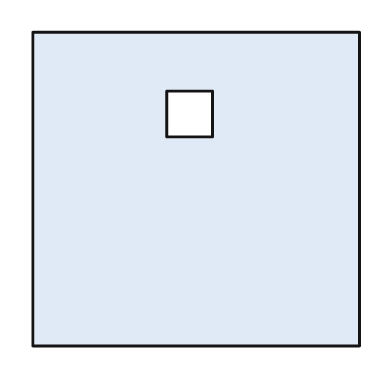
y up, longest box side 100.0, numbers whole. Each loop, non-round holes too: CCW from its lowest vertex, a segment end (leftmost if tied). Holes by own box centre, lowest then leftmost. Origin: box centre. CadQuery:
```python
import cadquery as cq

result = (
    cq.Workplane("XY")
    .moveTo(-50.0, -48.0)
    .lineTo(50.0, -48.0)
    .lineTo(50.0, 48.0)
    .lineTo(-50.0, 48.0)
    .close()
    .moveTo(-9.0, 16.0)
    .lineTo(5.0, 16.0)
    .lineTo(5.0, 30.0)
    .lineTo(-9.0, 30.0)
    .close()
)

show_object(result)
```